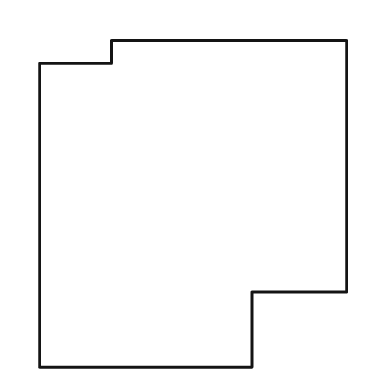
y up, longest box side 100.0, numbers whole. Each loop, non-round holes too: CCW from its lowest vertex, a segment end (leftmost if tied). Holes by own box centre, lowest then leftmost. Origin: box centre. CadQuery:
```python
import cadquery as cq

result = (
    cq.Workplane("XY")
    .moveTo(-47.0, -50.0)
    .lineTo(18.0, -50.0)
    .lineTo(18.0, -27.0)
    .lineTo(47.0, -27.0)
    .lineTo(47.0, 50.0)
    .lineTo(-25.0, 50.0)
    .lineTo(-25.0, 43.0)
    .lineTo(-47.0, 43.0)
    .close()
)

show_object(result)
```